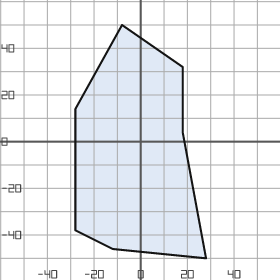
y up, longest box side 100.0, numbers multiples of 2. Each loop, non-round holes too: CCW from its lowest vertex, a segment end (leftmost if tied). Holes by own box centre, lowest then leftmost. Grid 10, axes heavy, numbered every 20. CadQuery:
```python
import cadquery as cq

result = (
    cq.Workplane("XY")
    .moveTo(28.0, -50.0)
    .lineTo(18.0, 4.0)
    .lineTo(18.0, 32.0)
    .lineTo(-8.0, 50.0)
    .lineTo(-28.0, 14.0)
    .lineTo(-28.0, -38.0)
    .lineTo(-12.0, -46.0)
    .close()
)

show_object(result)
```